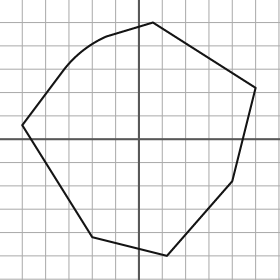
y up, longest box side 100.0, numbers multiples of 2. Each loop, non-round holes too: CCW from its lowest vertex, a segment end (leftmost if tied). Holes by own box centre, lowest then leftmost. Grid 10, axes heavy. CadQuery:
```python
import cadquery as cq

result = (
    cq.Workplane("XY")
    .moveTo(12.0, -50.0)
    .lineTo(40.0, -18.0)
    .lineTo(50.0, 22.0)
    .lineTo(6.0, 50.0)
    .lineTo(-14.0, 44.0)
    .threePointArc((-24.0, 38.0), (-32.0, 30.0))
    .lineTo(-50.0, 6.0)
    .lineTo(-20.0, -42.0)
    .close()
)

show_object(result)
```